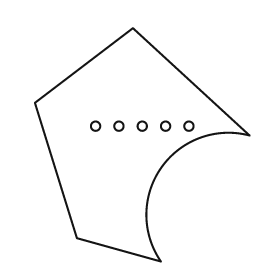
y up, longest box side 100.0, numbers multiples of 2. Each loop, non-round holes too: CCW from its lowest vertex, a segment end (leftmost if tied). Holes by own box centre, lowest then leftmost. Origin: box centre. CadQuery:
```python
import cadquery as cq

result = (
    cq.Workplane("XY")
    .moveTo(8.0, -50.0)
    .threePointArc((8.0, -10.0), (46.0, 4.0))
    .lineTo(-4.0, 50.0)
    .lineTo(-46.0, 18.0)
    .lineTo(-28.0, -40.0)
    .close()
    .moveTo(-20.0, 8.0)
    .circle(2.0)
    .moveTo(-10.0, 8.0)
    .circle(2.0)
    .moveTo(0.0, 8.0)
    .circle(2.0)
    .moveTo(10.0, 8.0)
    .circle(2.0)
    .moveTo(20.0, 8.0)
    .circle(2.0)
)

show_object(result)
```